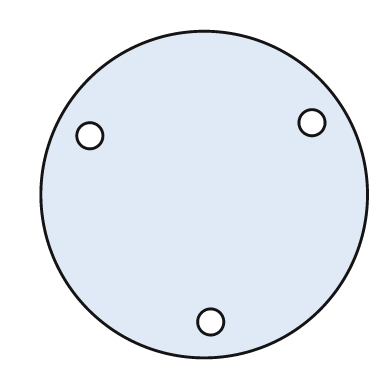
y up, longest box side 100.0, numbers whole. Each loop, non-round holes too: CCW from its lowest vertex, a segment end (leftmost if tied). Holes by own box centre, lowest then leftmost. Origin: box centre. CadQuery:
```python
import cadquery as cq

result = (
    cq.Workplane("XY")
    .moveTo(0.0, 0.0)
    .circle(50.0)
    .moveTo(2.0, -39.0)
    .circle(4.0)
    .moveTo(-35.0, 18.0)
    .circle(4.0)
    .moveTo(33.0, 22.0)
    .circle(4.0)
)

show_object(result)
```